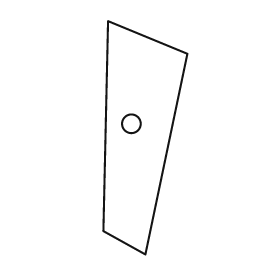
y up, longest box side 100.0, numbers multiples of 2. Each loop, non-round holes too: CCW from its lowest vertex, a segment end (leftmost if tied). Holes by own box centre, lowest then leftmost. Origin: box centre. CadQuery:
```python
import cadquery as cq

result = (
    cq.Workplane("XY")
    .moveTo(0.0, -50.0)
    .lineTo(18.0, 36.0)
    .lineTo(-16.0, 50.0)
    .lineTo(-18.0, -40.0)
    .close()
    .moveTo(-6.0, 6.0)
    .circle(4.0)
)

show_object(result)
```